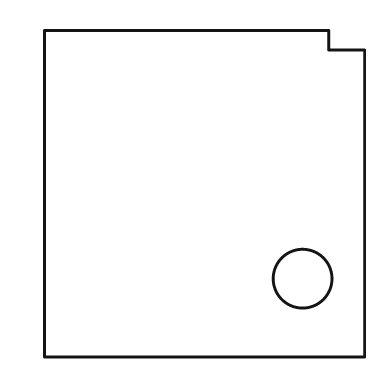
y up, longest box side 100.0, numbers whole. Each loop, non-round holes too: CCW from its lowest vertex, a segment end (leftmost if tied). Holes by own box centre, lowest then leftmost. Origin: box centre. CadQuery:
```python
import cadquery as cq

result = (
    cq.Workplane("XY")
    .moveTo(-49.0, -50.0)
    .lineTo(49.0, -50.0)
    .lineTo(49.0, 44.0)
    .lineTo(38.0, 44.0)
    .lineTo(38.0, 50.0)
    .lineTo(-49.0, 50.0)
    .close()
    .moveTo(30.0, -26.0)
    .circle(9.0)
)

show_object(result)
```